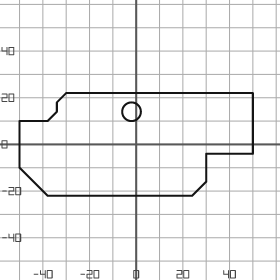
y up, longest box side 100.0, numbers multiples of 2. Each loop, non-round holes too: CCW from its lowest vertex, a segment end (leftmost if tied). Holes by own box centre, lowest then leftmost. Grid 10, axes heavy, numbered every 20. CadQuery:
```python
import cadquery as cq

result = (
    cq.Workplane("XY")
    .moveTo(-38.0, -22.0)
    .lineTo(24.0, -22.0)
    .lineTo(30.0, -16.0)
    .lineTo(30.0, -4.0)
    .lineTo(50.0, -4.0)
    .lineTo(50.0, 22.0)
    .lineTo(-30.0, 22.0)
    .lineTo(-34.0, 18.0)
    .lineTo(-34.0, 14.0)
    .lineTo(-38.0, 10.0)
    .lineTo(-50.0, 10.0)
    .lineTo(-50.0, -10.0)
    .close()
    .moveTo(-2.0, 14.0)
    .circle(4.0)
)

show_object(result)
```